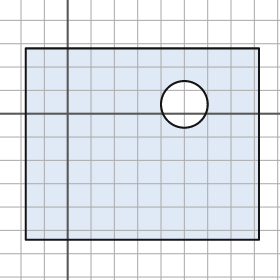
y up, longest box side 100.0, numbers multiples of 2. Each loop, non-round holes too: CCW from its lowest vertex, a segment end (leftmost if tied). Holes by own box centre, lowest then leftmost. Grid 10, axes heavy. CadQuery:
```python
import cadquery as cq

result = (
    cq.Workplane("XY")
    .moveTo(-18.0, -54.0)
    .lineTo(82.0, -54.0)
    .lineTo(82.0, 28.0)
    .lineTo(-18.0, 28.0)
    .close()
    .moveTo(50.0, 4.0)
    .circle(10.0)
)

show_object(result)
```